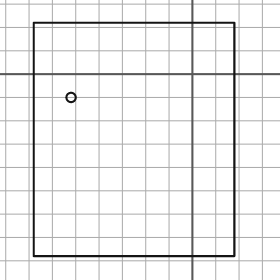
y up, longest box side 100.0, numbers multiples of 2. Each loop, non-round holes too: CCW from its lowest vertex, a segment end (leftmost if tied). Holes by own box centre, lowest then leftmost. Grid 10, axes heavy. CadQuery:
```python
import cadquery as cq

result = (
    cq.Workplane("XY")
    .moveTo(-68.0, -78.0)
    .lineTo(18.0, -78.0)
    .lineTo(18.0, 22.0)
    .lineTo(-68.0, 22.0)
    .close()
    .moveTo(-52.0, -10.0)
    .circle(2.0)
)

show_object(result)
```